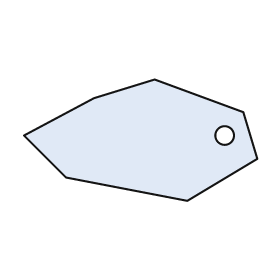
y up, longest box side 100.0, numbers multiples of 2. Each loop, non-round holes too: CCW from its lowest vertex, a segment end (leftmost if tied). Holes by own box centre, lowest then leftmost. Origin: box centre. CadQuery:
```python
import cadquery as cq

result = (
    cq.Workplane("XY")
    .moveTo(20.0, -26.0)
    .lineTo(50.0, -8.0)
    .lineTo(44.0, 12.0)
    .lineTo(6.0, 26.0)
    .lineTo(-20.0, 18.0)
    .lineTo(-50.0, 2.0)
    .lineTo(-32.0, -16.0)
    .close()
    .moveTo(36.0, 2.0)
    .circle(4.0)
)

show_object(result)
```